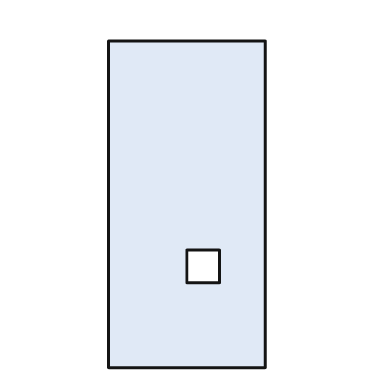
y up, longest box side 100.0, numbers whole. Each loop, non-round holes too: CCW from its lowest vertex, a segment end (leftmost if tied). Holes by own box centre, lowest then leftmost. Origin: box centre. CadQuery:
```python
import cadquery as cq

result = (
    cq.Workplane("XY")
    .moveTo(-24.0, -50.0)
    .lineTo(24.0, -50.0)
    .lineTo(24.0, 50.0)
    .lineTo(-24.0, 50.0)
    .close()
    .moveTo(0.0, -24.0)
    .lineTo(10.0, -24.0)
    .lineTo(10.0, -14.0)
    .lineTo(0.0, -14.0)
    .close()
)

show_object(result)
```